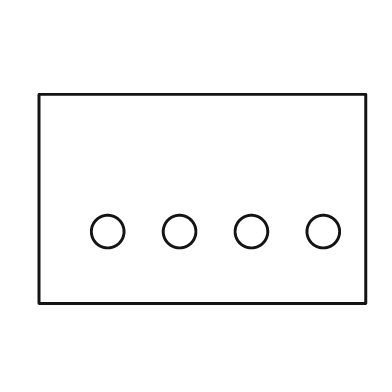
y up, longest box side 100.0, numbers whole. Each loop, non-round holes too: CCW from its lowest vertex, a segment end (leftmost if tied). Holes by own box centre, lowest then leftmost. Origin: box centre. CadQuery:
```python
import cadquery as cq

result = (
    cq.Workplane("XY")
    .moveTo(-50.0, -32.0)
    .lineTo(50.0, -32.0)
    .lineTo(50.0, 32.0)
    .lineTo(-50.0, 32.0)
    .close()
    .moveTo(-29.0, -10.0)
    .circle(5.0)
    .moveTo(-7.0, -10.0)
    .circle(5.0)
    .moveTo(15.0, -10.0)
    .circle(5.0)
    .moveTo(37.0, -10.0)
    .circle(5.0)
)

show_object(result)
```